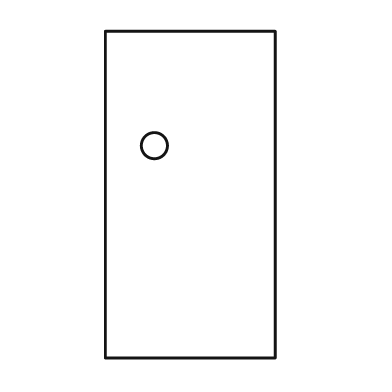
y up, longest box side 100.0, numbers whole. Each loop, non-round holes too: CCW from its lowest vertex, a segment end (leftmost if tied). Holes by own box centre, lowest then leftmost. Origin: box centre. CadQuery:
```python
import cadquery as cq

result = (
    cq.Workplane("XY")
    .moveTo(-26.0, -50.0)
    .lineTo(26.0, -50.0)
    .lineTo(26.0, 50.0)
    .lineTo(-26.0, 50.0)
    .close()
    .moveTo(-11.0, 15.0)
    .circle(4.0)
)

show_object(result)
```